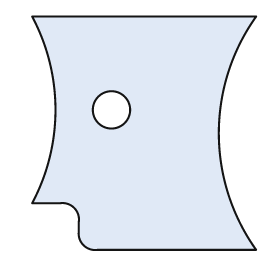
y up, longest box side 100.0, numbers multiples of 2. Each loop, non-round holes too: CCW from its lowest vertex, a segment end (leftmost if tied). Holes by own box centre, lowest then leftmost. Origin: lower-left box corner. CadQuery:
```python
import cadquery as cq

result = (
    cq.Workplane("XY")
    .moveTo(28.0, 0.0)
    .lineTo(96.0, 0.0)
    .threePointArc((80.0, 50.0), (96.0, 100.0))
    .lineTo(0.0, 100.0)
    .threePointArc((10.0, 60.0), (0.0, 20.0))
    .lineTo(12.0, 20.0)
    .threePointArc((18.0, 18.0), (20.0, 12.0))
    .lineTo(20.0, 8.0)
    .threePointArc((22.0, 2.0), (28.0, 0.0))
    .close()
    .moveTo(34.0, 60.0)
    .circle(8.0)
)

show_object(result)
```